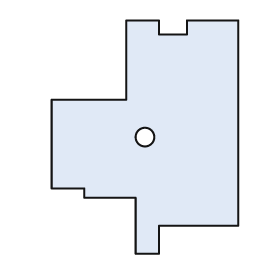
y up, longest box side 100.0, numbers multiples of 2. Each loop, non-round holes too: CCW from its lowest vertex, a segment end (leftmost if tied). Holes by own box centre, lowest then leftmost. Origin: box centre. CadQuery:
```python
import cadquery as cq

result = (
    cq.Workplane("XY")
    .moveTo(-4.0, -50.0)
    .lineTo(6.0, -50.0)
    .lineTo(6.0, -38.0)
    .lineTo(40.0, -38.0)
    .lineTo(40.0, 50.0)
    .lineTo(18.0, 50.0)
    .lineTo(18.0, 44.0)
    .lineTo(6.0, 44.0)
    .lineTo(6.0, 50.0)
    .lineTo(-8.0, 50.0)
    .lineTo(-8.0, 16.0)
    .lineTo(-40.0, 16.0)
    .lineTo(-40.0, -22.0)
    .lineTo(-26.0, -22.0)
    .lineTo(-26.0, -26.0)
    .lineTo(-4.0, -26.0)
    .close()
    .moveTo(0.0, 0.0)
    .circle(4.0)
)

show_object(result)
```